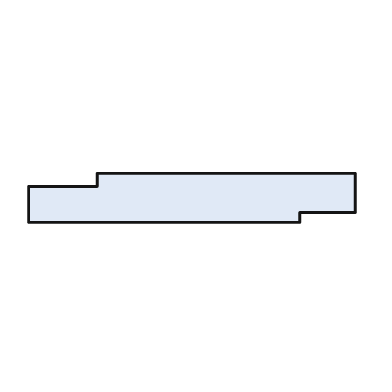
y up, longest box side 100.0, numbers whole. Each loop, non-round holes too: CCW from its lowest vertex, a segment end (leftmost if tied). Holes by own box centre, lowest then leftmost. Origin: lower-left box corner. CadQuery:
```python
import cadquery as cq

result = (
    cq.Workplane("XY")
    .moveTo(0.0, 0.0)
    .lineTo(83.0, 0.0)
    .lineTo(83.0, 3.0)
    .lineTo(100.0, 3.0)
    .lineTo(100.0, 15.0)
    .lineTo(21.0, 15.0)
    .lineTo(21.0, 11.0)
    .lineTo(0.0, 11.0)
    .close()
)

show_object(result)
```